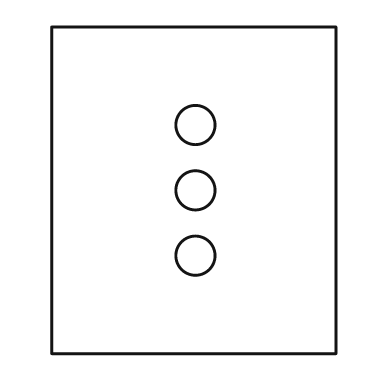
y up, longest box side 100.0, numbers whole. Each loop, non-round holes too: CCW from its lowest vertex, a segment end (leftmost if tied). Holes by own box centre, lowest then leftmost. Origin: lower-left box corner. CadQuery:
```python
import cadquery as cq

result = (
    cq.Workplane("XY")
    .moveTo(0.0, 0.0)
    .lineTo(87.0, 0.0)
    .lineTo(87.0, 100.0)
    .lineTo(0.0, 100.0)
    .close()
    .moveTo(44.0, 30.0)
    .circle(6.0)
    .moveTo(44.0, 50.0)
    .circle(6.0)
    .moveTo(44.0, 70.0)
    .circle(6.0)
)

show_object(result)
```